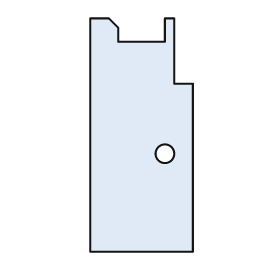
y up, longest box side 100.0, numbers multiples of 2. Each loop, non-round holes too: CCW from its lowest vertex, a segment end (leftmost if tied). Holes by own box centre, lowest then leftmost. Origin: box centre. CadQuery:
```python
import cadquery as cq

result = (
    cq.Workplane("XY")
    .moveTo(-22.0, -50.0)
    .lineTo(22.0, -50.0)
    .lineTo(22.0, 22.0)
    .lineTo(14.0, 22.0)
    .lineTo(14.0, 50.0)
    .lineTo(10.0, 50.0)
    .lineTo(10.0, 40.0)
    .lineTo(-10.0, 40.0)
    .lineTo(-10.0, 46.0)
    .lineTo(-14.0, 50.0)
    .lineTo(-22.0, 50.0)
    .close()
    .moveTo(10.0, -8.0)
    .circle(4.0)
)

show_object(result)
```